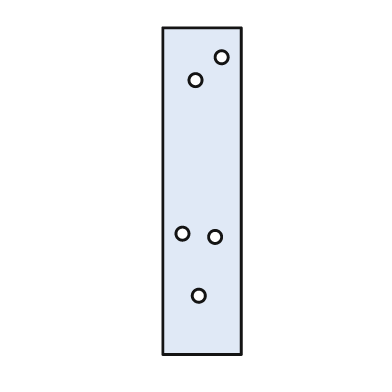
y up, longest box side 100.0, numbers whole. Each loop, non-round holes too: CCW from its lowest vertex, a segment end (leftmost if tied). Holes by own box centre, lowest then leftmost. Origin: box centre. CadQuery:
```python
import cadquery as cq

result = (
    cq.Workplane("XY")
    .moveTo(-12.0, -50.0)
    .lineTo(12.0, -50.0)
    .lineTo(12.0, 50.0)
    .lineTo(-12.0, 50.0)
    .close()
    .moveTo(-1.0, -32.0)
    .circle(2.0)
    .moveTo(4.0, -14.0)
    .circle(2.0)
    .moveTo(-6.0, -13.0)
    .circle(2.0)
    .moveTo(-2.0, 34.0)
    .circle(2.0)
    .moveTo(6.0, 41.0)
    .circle(2.0)
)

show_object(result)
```